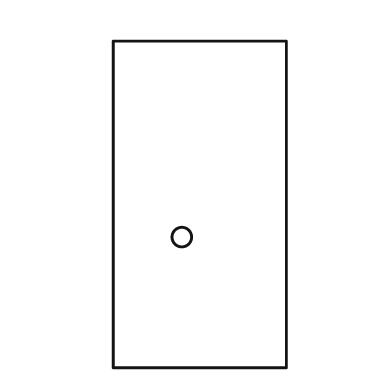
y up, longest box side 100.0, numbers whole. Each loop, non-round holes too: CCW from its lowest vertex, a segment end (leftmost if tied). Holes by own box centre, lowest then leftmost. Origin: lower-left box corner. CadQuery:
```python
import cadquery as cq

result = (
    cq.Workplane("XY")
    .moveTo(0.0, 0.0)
    .lineTo(53.0, 0.0)
    .lineTo(53.0, 100.0)
    .lineTo(0.0, 100.0)
    .close()
    .moveTo(21.0, 40.0)
    .circle(3.0)
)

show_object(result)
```